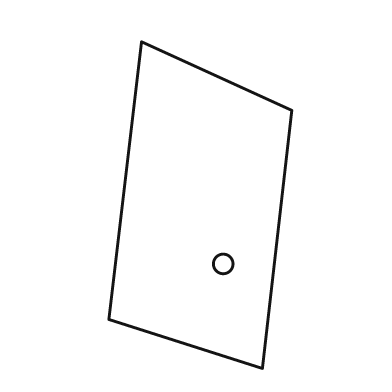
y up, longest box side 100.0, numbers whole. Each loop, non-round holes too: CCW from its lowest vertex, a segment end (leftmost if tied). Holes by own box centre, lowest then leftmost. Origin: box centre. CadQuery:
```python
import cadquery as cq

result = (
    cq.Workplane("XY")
    .moveTo(19.0, -50.0)
    .lineTo(28.0, 29.0)
    .lineTo(-18.0, 50.0)
    .lineTo(-28.0, -35.0)
    .close()
    .moveTo(7.0, -18.0)
    .circle(3.0)
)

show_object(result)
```